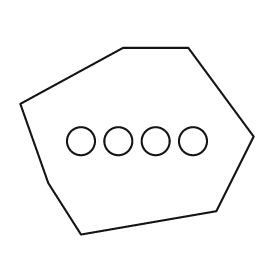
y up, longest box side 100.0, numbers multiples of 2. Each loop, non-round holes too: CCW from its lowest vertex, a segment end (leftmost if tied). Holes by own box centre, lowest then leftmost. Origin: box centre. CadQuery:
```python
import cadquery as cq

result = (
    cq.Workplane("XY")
    .moveTo(-24.0, -40.0)
    .lineTo(34.0, -30.0)
    .lineTo(50.0, 2.0)
    .lineTo(22.0, 40.0)
    .lineTo(-6.0, 40.0)
    .lineTo(-50.0, 16.0)
    .lineTo(-38.0, -18.0)
    .close()
    .moveTo(-24.0, 0.0)
    .circle(6.0)
    .moveTo(-8.0, 0.0)
    .circle(6.0)
    .moveTo(8.0, 0.0)
    .circle(6.0)
    .moveTo(24.0, 0.0)
    .circle(6.0)
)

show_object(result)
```